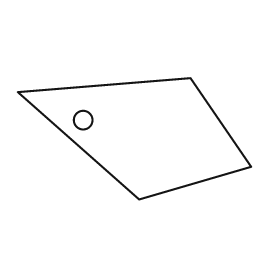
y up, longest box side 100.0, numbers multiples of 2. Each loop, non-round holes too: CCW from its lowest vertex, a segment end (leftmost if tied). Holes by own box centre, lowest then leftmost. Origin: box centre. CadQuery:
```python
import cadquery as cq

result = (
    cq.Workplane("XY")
    .moveTo(2.0, -26.0)
    .lineTo(50.0, -12.0)
    .lineTo(24.0, 26.0)
    .lineTo(-50.0, 20.0)
    .close()
    .moveTo(-22.0, 8.0)
    .circle(4.0)
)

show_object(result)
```